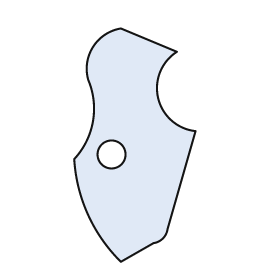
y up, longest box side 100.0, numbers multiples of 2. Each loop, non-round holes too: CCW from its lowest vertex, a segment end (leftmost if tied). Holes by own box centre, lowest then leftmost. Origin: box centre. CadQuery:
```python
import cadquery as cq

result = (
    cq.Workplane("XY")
    .moveTo(-6.0, -50.0)
    .lineTo(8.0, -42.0)
    .threePointArc((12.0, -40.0), (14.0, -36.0))
    .lineTo(26.0, 6.0)
    .threePointArc((10.0, 20.0), (18.0, 40.0))
    .lineTo(-6.0, 50.0)
    .threePointArc((-18.0, 42.0), (-20.0, 28.0))
    .threePointArc((-18.0, 10.0), (-26.0, -6.0))
    .threePointArc((-20.0, -30.0), (-6.0, -50.0))
    .close()
    .moveTo(-10.0, -4.0)
    .circle(6.0)
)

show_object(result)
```